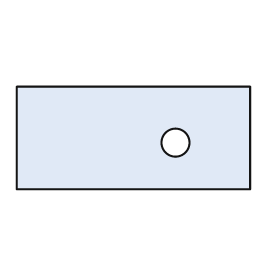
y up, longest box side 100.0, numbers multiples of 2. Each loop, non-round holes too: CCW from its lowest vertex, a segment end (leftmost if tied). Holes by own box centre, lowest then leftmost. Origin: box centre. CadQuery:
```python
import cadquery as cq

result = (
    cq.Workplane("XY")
    .moveTo(-50.0, -22.0)
    .lineTo(50.0, -22.0)
    .lineTo(50.0, 22.0)
    .lineTo(-50.0, 22.0)
    .close()
    .moveTo(18.0, -2.0)
    .circle(6.0)
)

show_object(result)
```